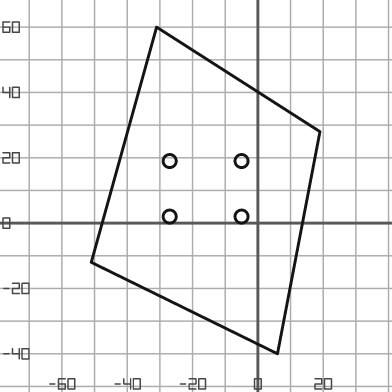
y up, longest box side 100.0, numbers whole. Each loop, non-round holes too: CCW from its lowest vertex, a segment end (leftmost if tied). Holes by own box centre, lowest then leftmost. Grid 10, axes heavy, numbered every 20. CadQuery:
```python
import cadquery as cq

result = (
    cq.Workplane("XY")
    .moveTo(6.0, -40.0)
    .lineTo(19.0, 28.0)
    .lineTo(-31.0, 60.0)
    .lineTo(-51.0, -12.0)
    .close()
    .moveTo(-27.0, 2.0)
    .circle(2.0)
    .moveTo(-5.0, 2.0)
    .circle(2.0)
    .moveTo(-27.0, 19.0)
    .circle(2.0)
    .moveTo(-5.0, 19.0)
    .circle(2.0)
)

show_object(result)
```